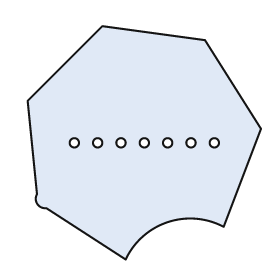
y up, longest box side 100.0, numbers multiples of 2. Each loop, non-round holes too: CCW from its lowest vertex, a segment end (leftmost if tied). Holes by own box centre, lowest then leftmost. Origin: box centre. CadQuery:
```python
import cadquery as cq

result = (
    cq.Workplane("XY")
    .moveTo(-8.0, -50.0)
    .threePointArc((10.0, -34.0), (34.0, -36.0))
    .lineTo(50.0, 6.0)
    .lineTo(26.0, 44.0)
    .lineTo(-18.0, 50.0)
    .lineTo(-50.0, 18.0)
    .lineTo(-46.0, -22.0)
    .threePointArc((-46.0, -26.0), (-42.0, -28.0))
    .close()
    .moveTo(-30.0, 0.0)
    .circle(2.0)
    .moveTo(-20.0, 0.0)
    .circle(2.0)
    .moveTo(-10.0, 0.0)
    .circle(2.0)
    .moveTo(0.0, 0.0)
    .circle(2.0)
    .moveTo(10.0, 0.0)
    .circle(2.0)
    .moveTo(20.0, 0.0)
    .circle(2.0)
    .moveTo(30.0, 0.0)
    .circle(2.0)
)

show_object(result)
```